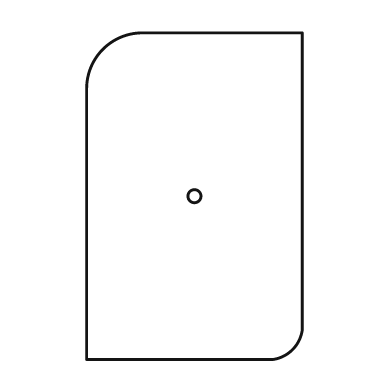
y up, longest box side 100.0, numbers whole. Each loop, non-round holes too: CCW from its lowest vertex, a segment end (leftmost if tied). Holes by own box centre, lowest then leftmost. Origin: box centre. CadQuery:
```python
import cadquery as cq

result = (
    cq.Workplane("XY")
    .moveTo(-33.0, -50.0)
    .lineTo(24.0, -50.0)
    .threePointArc((30.0, -47.0), (33.0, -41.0))
    .lineTo(33.0, 50.0)
    .lineTo(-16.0, 50.0)
    .threePointArc((-28.0, 45.0), (-33.0, 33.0))
    .close()
    .moveTo(0.0, 0.0)
    .circle(2.0)
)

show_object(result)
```